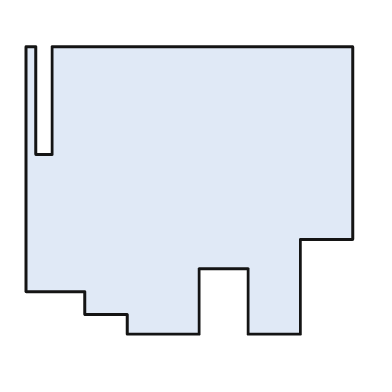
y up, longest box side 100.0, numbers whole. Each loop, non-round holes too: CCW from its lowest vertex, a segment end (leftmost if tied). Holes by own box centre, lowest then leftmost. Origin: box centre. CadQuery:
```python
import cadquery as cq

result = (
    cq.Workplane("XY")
    .moveTo(-19.0, -44.0)
    .lineTo(3.0, -44.0)
    .lineTo(3.0, -24.0)
    .lineTo(18.0, -24.0)
    .lineTo(18.0, -44.0)
    .lineTo(34.0, -44.0)
    .lineTo(34.0, -15.0)
    .lineTo(50.0, -15.0)
    .lineTo(50.0, 44.0)
    .lineTo(-42.0, 44.0)
    .lineTo(-42.0, 11.0)
    .lineTo(-47.0, 11.0)
    .lineTo(-47.0, 44.0)
    .lineTo(-50.0, 44.0)
    .lineTo(-50.0, -31.0)
    .lineTo(-32.0, -31.0)
    .lineTo(-32.0, -38.0)
    .lineTo(-19.0, -38.0)
    .close()
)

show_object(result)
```